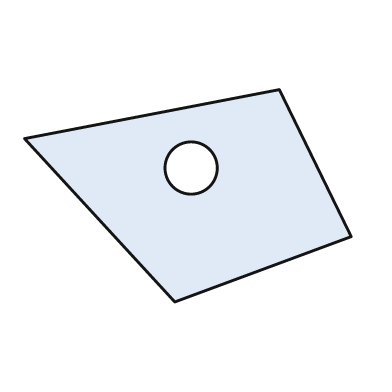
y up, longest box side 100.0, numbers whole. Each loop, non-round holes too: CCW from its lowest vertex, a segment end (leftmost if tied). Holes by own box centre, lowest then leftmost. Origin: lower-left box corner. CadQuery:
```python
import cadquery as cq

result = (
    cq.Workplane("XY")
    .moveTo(46.0, 0.0)
    .lineTo(100.0, 20.0)
    .lineTo(78.0, 65.0)
    .lineTo(0.0, 50.0)
    .close()
    .moveTo(51.0, 41.0)
    .circle(8.0)
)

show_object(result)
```